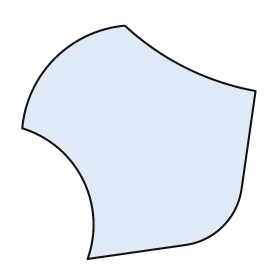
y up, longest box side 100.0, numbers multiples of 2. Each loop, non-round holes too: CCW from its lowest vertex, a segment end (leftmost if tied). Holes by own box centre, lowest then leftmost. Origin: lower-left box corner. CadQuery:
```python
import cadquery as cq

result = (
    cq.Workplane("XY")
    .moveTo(28.0, 0.0)
    .lineTo(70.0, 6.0)
    .threePointArc((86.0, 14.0), (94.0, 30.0))
    .lineTo(100.0, 72.0)
    .threePointArc((70.0, 82.0), (44.0, 100.0))
    .threePointArc((14.0, 86.0), (0.0, 56.0))
    .threePointArc((26.0, 34.0), (28.0, 0.0))
    .close()
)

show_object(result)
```